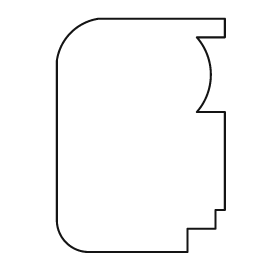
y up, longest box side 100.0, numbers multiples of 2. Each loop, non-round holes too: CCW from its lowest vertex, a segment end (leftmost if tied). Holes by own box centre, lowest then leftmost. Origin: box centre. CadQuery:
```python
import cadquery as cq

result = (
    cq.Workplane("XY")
    .moveTo(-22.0, -50.0)
    .lineTo(20.0, -50.0)
    .lineTo(20.0, -40.0)
    .lineTo(32.0, -40.0)
    .lineTo(32.0, -32.0)
    .lineTo(36.0, -32.0)
    .lineTo(36.0, 10.0)
    .lineTo(24.0, 10.0)
    .threePointArc((30.0, 26.0), (24.0, 42.0))
    .lineTo(36.0, 42.0)
    .lineTo(36.0, 50.0)
    .lineTo(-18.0, 50.0)
    .threePointArc((-30.0, 44.0), (-36.0, 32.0))
    .lineTo(-36.0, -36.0)
    .threePointArc((-32.0, -46.0), (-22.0, -50.0))
    .close()
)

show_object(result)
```